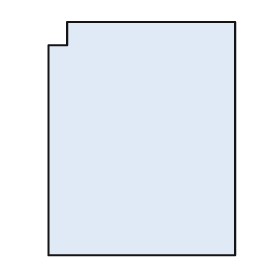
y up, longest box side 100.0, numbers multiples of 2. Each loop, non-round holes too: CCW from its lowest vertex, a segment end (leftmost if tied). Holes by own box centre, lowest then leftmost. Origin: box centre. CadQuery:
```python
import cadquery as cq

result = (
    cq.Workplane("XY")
    .moveTo(-40.0, -50.0)
    .lineTo(40.0, -50.0)
    .lineTo(40.0, 50.0)
    .lineTo(-32.0, 50.0)
    .lineTo(-32.0, 40.0)
    .lineTo(-40.0, 40.0)
    .close()
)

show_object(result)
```